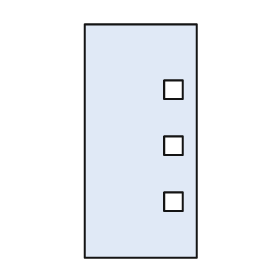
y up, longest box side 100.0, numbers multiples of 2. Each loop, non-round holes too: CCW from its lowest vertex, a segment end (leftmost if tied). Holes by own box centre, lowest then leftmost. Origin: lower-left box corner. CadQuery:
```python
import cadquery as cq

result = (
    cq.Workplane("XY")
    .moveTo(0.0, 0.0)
    .lineTo(48.0, 0.0)
    .lineTo(48.0, 100.0)
    .lineTo(0.0, 100.0)
    .close()
    .moveTo(34.0, 20.0)
    .lineTo(42.0, 20.0)
    .lineTo(42.0, 28.0)
    .lineTo(34.0, 28.0)
    .close()
    .moveTo(34.0, 44.0)
    .lineTo(42.0, 44.0)
    .lineTo(42.0, 52.0)
    .lineTo(34.0, 52.0)
    .close()
    .moveTo(34.0, 68.0)
    .lineTo(42.0, 68.0)
    .lineTo(42.0, 76.0)
    .lineTo(34.0, 76.0)
    .close()
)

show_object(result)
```